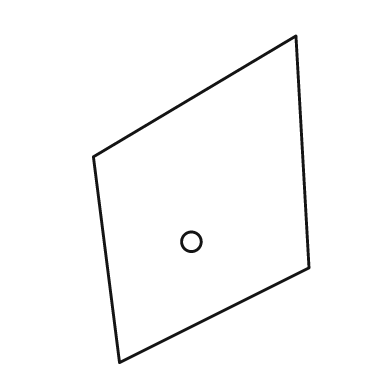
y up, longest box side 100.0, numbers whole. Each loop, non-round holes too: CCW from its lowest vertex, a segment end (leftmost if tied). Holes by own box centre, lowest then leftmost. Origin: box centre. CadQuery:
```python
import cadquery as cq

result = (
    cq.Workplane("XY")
    .moveTo(-25.0, -50.0)
    .lineTo(33.0, -21.0)
    .lineTo(29.0, 50.0)
    .lineTo(-33.0, 13.0)
    .close()
    .moveTo(-3.0, -13.0)
    .circle(3.0)
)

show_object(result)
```